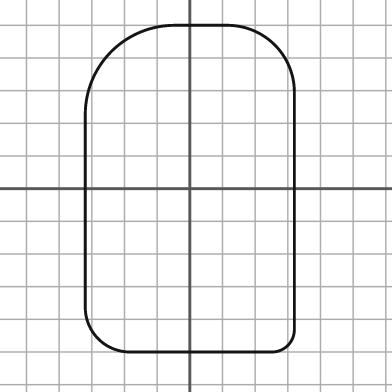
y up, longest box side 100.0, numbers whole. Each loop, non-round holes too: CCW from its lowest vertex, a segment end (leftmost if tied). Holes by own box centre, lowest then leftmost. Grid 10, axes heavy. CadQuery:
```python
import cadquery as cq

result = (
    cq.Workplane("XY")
    .moveTo(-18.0, -50.0)
    .lineTo(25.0, -50.0)
    .threePointArc((30.0, -48.0), (32.0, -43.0))
    .lineTo(32.0, 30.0)
    .threePointArc((26.0, 44.0), (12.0, 50.0))
    .lineTo(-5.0, 50.0)
    .threePointArc((-24.0, 42.0), (-32.0, 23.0))
    .lineTo(-32.0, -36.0)
    .threePointArc((-28.0, -46.0), (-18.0, -50.0))
    .close()
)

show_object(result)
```